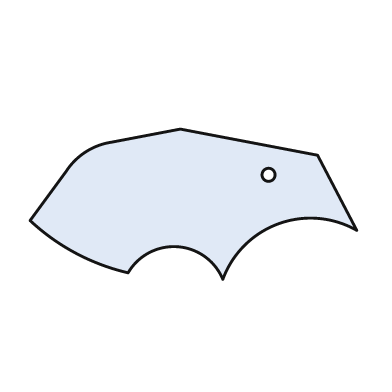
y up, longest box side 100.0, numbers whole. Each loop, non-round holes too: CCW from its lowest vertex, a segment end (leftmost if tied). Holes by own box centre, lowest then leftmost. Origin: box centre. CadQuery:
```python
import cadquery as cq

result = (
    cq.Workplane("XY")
    .moveTo(9.0, -23.0)
    .threePointArc((26.0, -6.0), (50.0, -8.0))
    .lineTo(38.0, 15.0)
    .lineTo(-4.0, 23.0)
    .lineTo(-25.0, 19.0)
    .threePointArc((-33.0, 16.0), (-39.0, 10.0))
    .lineTo(-50.0, -5.0)
    .threePointArc((-36.0, -15.0), (-20.0, -21.0))
    .threePointArc((-5.0, -13.0), (9.0, -23.0))
    .close()
    .moveTo(23.0, 9.0)
    .circle(2.0)
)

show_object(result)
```